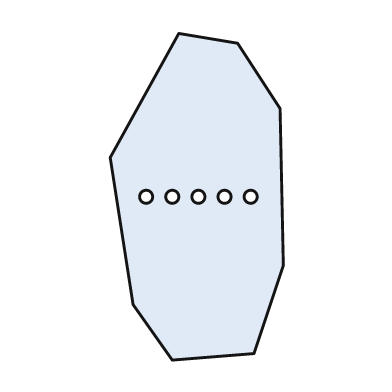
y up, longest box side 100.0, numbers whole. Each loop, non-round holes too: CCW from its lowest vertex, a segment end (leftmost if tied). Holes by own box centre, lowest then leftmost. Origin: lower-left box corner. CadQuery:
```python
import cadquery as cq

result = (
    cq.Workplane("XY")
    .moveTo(19.0, 0.0)
    .lineTo(44.0, 2.0)
    .lineTo(53.0, 29.0)
    .lineTo(52.0, 77.0)
    .lineTo(39.0, 97.0)
    .lineTo(21.0, 100.0)
    .lineTo(0.0, 62.0)
    .lineTo(7.0, 17.0)
    .close()
    .moveTo(11.0, 50.0)
    .circle(2.0)
    .moveTo(19.0, 50.0)
    .circle(2.0)
    .moveTo(27.0, 50.0)
    .circle(2.0)
    .moveTo(35.0, 50.0)
    .circle(2.0)
    .moveTo(43.0, 50.0)
    .circle(2.0)
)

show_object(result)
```